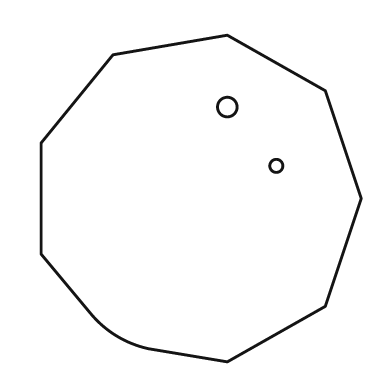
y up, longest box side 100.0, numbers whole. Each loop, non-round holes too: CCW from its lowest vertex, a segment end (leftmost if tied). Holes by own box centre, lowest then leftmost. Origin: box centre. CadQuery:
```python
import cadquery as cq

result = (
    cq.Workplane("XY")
    .moveTo(8.0, -50.0)
    .lineTo(38.0, -33.0)
    .lineTo(49.0, 0.0)
    .lineTo(38.0, 33.0)
    .lineTo(8.0, 50.0)
    .lineTo(-27.0, 44.0)
    .lineTo(-49.0, 17.0)
    .lineTo(-49.0, -17.0)
    .lineTo(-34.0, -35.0)
    .threePointArc((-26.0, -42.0), (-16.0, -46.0))
    .close()
    .moveTo(23.0, 10.0)
    .circle(2.0)
    .moveTo(8.0, 28.0)
    .circle(3.0)
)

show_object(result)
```